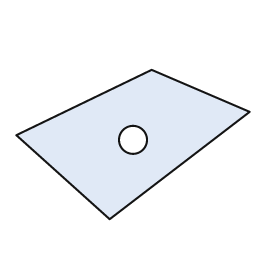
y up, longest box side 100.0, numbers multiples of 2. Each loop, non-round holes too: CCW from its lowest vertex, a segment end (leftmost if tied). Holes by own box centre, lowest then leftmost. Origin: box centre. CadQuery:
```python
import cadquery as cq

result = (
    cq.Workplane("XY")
    .moveTo(-10.0, -32.0)
    .lineTo(50.0, 14.0)
    .lineTo(8.0, 32.0)
    .lineTo(-50.0, 4.0)
    .close()
    .moveTo(0.0, 2.0)
    .circle(6.0)
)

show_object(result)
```